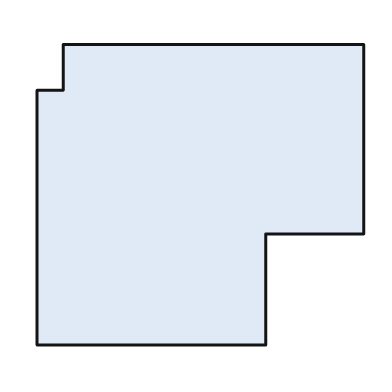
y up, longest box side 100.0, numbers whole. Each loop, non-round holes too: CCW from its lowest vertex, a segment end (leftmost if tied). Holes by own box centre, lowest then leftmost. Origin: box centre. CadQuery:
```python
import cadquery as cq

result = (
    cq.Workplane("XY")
    .moveTo(-50.0, -46.0)
    .lineTo(20.0, -46.0)
    .lineTo(20.0, -12.0)
    .lineTo(50.0, -12.0)
    .lineTo(50.0, 46.0)
    .lineTo(-42.0, 46.0)
    .lineTo(-42.0, 32.0)
    .lineTo(-50.0, 32.0)
    .close()
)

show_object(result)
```